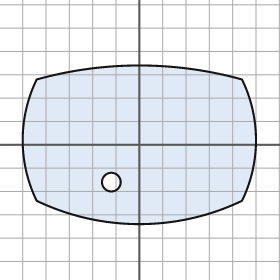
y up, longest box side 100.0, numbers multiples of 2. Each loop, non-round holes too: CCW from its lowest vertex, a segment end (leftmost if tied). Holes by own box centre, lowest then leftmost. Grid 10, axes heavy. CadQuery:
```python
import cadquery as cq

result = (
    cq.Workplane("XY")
    .moveTo(-44.0, -24.0)
    .threePointArc((0.0, -34.0), (44.0, -24.0))
    .threePointArc((50.0, 2.0), (44.0, 28.0))
    .threePointArc((0.0, 34.0), (-44.0, 28.0))
    .threePointArc((-50.0, 2.0), (-44.0, -24.0))
    .close()
    .moveTo(-12.0, -16.0)
    .circle(4.0)
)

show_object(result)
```